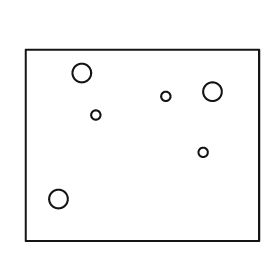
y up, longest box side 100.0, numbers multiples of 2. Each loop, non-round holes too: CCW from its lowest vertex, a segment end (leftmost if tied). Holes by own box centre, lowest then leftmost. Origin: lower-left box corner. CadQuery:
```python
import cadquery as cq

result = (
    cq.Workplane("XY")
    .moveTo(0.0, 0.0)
    .lineTo(100.0, 0.0)
    .lineTo(100.0, 82.0)
    .lineTo(0.0, 82.0)
    .close()
    .moveTo(14.0, 18.0)
    .circle(4.0)
    .moveTo(76.0, 38.0)
    .circle(2.0)
    .moveTo(30.0, 54.0)
    .circle(2.0)
    .moveTo(60.0, 62.0)
    .circle(2.0)
    .moveTo(80.0, 64.0)
    .circle(4.0)
    .moveTo(24.0, 72.0)
    .circle(4.0)
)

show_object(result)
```